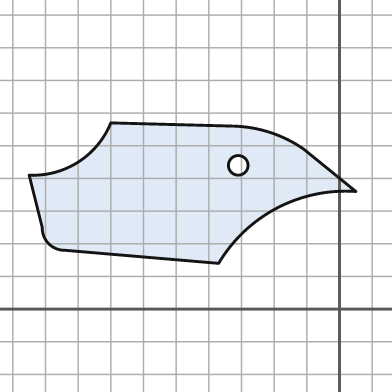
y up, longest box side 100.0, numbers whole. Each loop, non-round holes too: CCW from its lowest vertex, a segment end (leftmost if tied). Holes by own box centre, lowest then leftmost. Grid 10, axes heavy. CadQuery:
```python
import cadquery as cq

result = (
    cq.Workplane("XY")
    .moveTo(-37.0, 14.0)
    .threePointArc((-19.0, 31.0), (5.0, 36.0))
    .lineTo(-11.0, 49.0)
    .threePointArc((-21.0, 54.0), (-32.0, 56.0))
    .lineTo(-70.0, 57.0)
    .threePointArc((-80.0, 45.0), (-95.0, 41.0))
    .lineTo(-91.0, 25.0)
    .threePointArc((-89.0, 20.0), (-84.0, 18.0))
    .close()
    .moveTo(-31.0, 44.0)
    .circle(3.0)
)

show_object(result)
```